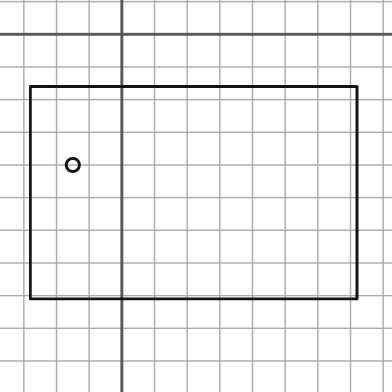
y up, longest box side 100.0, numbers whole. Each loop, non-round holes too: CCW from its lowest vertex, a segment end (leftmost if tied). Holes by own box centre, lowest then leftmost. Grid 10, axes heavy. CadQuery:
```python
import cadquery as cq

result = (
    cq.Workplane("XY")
    .moveTo(-28.0, -81.0)
    .lineTo(72.0, -81.0)
    .lineTo(72.0, -16.0)
    .lineTo(-28.0, -16.0)
    .close()
    .moveTo(-15.0, -40.0)
    .circle(2.0)
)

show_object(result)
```